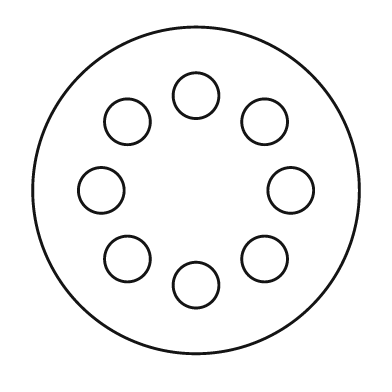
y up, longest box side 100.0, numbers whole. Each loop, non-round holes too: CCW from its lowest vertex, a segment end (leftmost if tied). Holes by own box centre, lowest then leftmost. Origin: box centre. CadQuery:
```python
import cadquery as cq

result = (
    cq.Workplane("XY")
    .moveTo(0.0, 0.0)
    .circle(50.0)
    .moveTo(0.0, -29.0)
    .circle(7.0)
    .moveTo(-21.0, -21.0)
    .circle(7.0)
    .moveTo(21.0, -21.0)
    .circle(7.0)
    .moveTo(-29.0, 0.0)
    .circle(7.0)
    .moveTo(29.0, 0.0)
    .circle(7.0)
    .moveTo(-21.0, 21.0)
    .circle(7.0)
    .moveTo(21.0, 21.0)
    .circle(7.0)
    .moveTo(0.0, 29.0)
    .circle(7.0)
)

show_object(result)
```